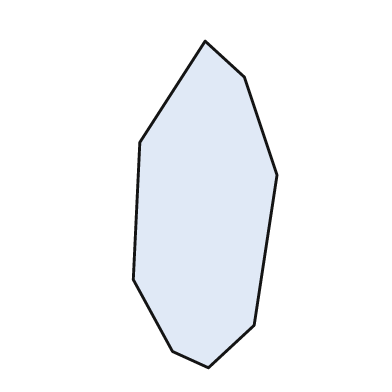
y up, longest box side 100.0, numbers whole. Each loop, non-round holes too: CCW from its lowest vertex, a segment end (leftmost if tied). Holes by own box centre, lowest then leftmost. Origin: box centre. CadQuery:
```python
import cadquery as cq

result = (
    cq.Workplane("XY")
    .moveTo(1.0, -50.0)
    .lineTo(15.0, -37.0)
    .lineTo(22.0, 9.0)
    .lineTo(12.0, 39.0)
    .lineTo(0.0, 50.0)
    .lineTo(-20.0, 19.0)
    .lineTo(-22.0, -23.0)
    .lineTo(-10.0, -45.0)
    .close()
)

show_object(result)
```